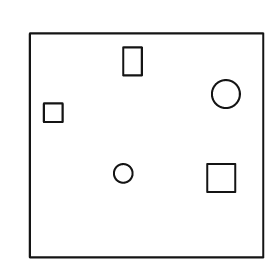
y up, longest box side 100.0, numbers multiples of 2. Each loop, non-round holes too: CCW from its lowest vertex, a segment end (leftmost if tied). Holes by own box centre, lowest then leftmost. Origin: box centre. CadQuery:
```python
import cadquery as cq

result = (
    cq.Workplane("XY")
    .moveTo(-50.0, -48.0)
    .lineTo(50.0, -48.0)
    .lineTo(50.0, 48.0)
    .lineTo(-50.0, 48.0)
    .close()
    .moveTo(26.0, -20.0)
    .lineTo(38.0, -20.0)
    .lineTo(38.0, -8.0)
    .lineTo(26.0, -8.0)
    .close()
    .moveTo(-10.0, -12.0)
    .circle(4.0)
    .moveTo(-44.0, 10.0)
    .lineTo(-36.0, 10.0)
    .lineTo(-36.0, 18.0)
    .lineTo(-44.0, 18.0)
    .close()
    .moveTo(34.0, 22.0)
    .circle(6.0)
    .moveTo(-10.0, 30.0)
    .lineTo(-2.0, 30.0)
    .lineTo(-2.0, 42.0)
    .lineTo(-10.0, 42.0)
    .close()
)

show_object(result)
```